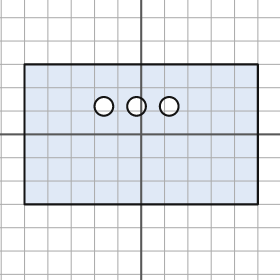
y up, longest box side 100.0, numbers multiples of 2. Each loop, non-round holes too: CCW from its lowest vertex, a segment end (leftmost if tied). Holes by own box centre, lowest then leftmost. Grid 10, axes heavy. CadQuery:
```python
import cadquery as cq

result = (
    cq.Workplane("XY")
    .moveTo(-50.0, -30.0)
    .lineTo(50.0, -30.0)
    .lineTo(50.0, 30.0)
    .lineTo(-50.0, 30.0)
    .close()
    .moveTo(-16.0, 12.0)
    .circle(4.0)
    .moveTo(-2.0, 12.0)
    .circle(4.0)
    .moveTo(12.0, 12.0)
    .circle(4.0)
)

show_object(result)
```